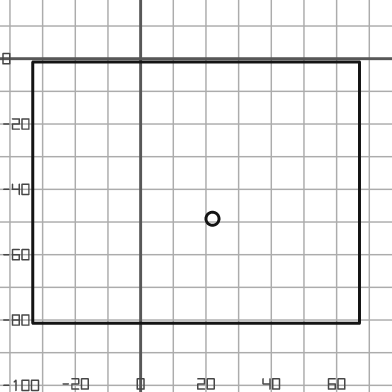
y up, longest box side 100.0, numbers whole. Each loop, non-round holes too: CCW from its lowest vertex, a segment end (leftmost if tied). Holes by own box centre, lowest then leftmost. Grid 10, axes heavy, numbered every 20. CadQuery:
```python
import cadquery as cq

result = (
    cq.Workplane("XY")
    .moveTo(-33.0, -81.0)
    .lineTo(67.0, -81.0)
    .lineTo(67.0, -1.0)
    .lineTo(-33.0, -1.0)
    .close()
    .moveTo(22.0, -49.0)
    .circle(2.0)
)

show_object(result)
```